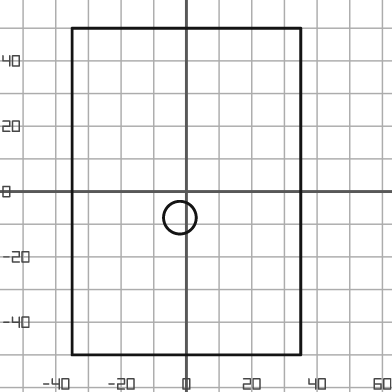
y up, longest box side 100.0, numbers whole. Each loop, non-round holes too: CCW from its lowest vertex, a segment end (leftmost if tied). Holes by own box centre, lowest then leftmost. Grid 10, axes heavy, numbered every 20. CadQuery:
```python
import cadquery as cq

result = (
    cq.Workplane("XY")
    .moveTo(-35.0, -50.0)
    .lineTo(35.0, -50.0)
    .lineTo(35.0, 50.0)
    .lineTo(-35.0, 50.0)
    .close()
    .moveTo(-2.0, -8.0)
    .circle(5.0)
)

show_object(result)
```